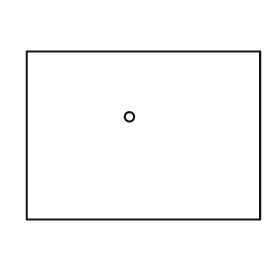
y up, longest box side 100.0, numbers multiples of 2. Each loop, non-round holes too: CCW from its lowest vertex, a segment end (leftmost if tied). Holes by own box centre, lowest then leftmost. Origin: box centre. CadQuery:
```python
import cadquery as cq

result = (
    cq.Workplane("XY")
    .moveTo(-50.0, -36.0)
    .lineTo(50.0, -36.0)
    .lineTo(50.0, 36.0)
    .lineTo(-50.0, 36.0)
    .close()
    .moveTo(-6.0, 8.0)
    .circle(2.0)
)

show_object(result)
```